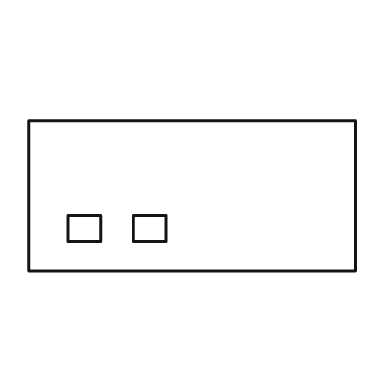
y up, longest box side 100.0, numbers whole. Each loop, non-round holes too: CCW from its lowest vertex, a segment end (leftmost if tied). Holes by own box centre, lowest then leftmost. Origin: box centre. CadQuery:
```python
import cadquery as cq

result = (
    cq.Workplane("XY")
    .moveTo(-50.0, -23.0)
    .lineTo(50.0, -23.0)
    .lineTo(50.0, 23.0)
    .lineTo(-50.0, 23.0)
    .close()
    .moveTo(-38.0, -14.0)
    .lineTo(-28.0, -14.0)
    .lineTo(-28.0, -6.0)
    .lineTo(-38.0, -6.0)
    .close()
    .moveTo(-18.0, -14.0)
    .lineTo(-8.0, -14.0)
    .lineTo(-8.0, -6.0)
    .lineTo(-18.0, -6.0)
    .close()
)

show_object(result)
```